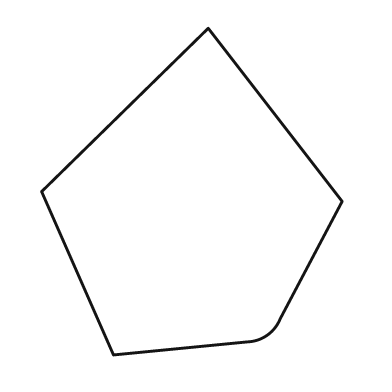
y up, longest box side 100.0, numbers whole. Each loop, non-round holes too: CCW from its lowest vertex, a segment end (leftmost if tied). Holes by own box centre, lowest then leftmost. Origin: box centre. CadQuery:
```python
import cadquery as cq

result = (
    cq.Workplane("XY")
    .moveTo(-24.0, -50.0)
    .lineTo(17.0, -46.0)
    .threePointArc((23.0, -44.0), (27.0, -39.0))
    .lineTo(46.0, -3.0)
    .lineTo(5.0, 50.0)
    .lineTo(-46.0, 0.0)
    .close()
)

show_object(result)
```